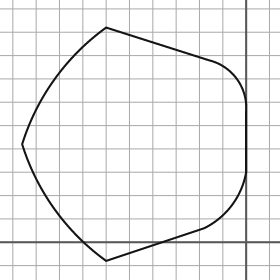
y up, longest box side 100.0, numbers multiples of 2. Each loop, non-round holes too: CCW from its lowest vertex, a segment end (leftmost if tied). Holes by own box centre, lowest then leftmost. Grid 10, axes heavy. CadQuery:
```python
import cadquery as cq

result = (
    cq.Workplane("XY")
    .moveTo(-60.0, -8.0)
    .lineTo(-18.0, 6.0)
    .threePointArc((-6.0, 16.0), (0.0, 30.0))
    .lineTo(0.0, 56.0)
    .threePointArc((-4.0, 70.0), (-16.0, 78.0))
    .lineTo(-60.0, 92.0)
    .threePointArc((-82.0, 70.0), (-96.0, 42.0))
    .threePointArc((-82.0, 14.0), (-60.0, -8.0))
    .close()
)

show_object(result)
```